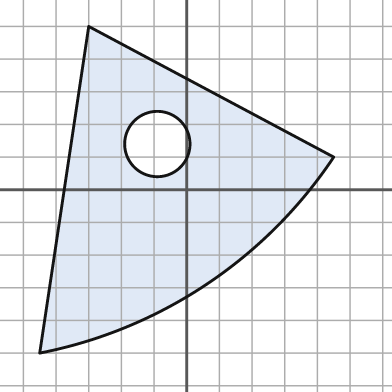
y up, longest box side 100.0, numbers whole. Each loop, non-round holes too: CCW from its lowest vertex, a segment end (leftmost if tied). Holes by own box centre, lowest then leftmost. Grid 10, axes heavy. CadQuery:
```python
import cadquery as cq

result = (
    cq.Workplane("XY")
    .moveTo(-45.0, -50.0)
    .threePointArc((6.0, -29.0), (45.0, 10.0))
    .lineTo(-30.0, 50.0)
    .close()
    .moveTo(-9.0, 14.0)
    .circle(10.0)
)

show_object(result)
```